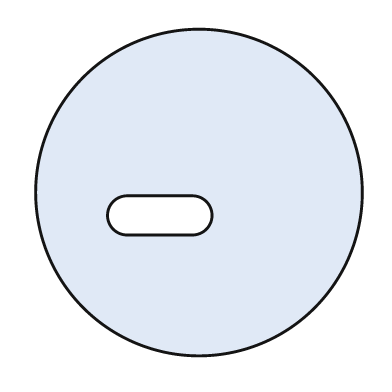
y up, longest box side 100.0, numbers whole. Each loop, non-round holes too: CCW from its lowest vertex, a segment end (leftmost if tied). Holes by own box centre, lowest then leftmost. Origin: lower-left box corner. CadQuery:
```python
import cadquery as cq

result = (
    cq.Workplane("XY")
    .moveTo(50.0, 50.0)
    .circle(50.0)
    .moveTo(28.0, 37.0)
    .lineTo(48.0, 37.0)
    .threePointArc((54.0, 43.0), (48.0, 49.0))
    .lineTo(28.0, 49.0)
    .threePointArc((22.0, 43.0), (28.0, 37.0))
    .close()
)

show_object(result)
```